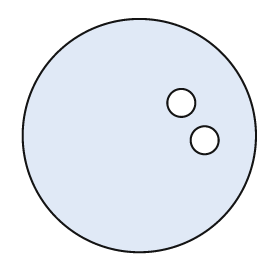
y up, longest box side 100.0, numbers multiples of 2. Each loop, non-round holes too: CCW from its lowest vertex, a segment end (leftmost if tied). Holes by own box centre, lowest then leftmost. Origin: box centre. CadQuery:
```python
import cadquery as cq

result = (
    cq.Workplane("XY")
    .moveTo(0.0, 0.0)
    .circle(50.0)
    .moveTo(28.0, -2.0)
    .circle(6.0)
    .moveTo(18.0, 14.0)
    .circle(6.0)
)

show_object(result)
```